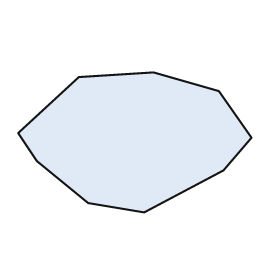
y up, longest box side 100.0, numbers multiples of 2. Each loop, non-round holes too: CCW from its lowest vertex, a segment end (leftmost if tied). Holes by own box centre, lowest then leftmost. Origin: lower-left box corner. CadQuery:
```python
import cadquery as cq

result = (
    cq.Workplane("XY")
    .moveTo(54.0, 0.0)
    .lineTo(88.0, 18.0)
    .lineTo(100.0, 32.0)
    .lineTo(86.0, 52.0)
    .lineTo(58.0, 60.0)
    .lineTo(26.0, 58.0)
    .lineTo(0.0, 34.0)
    .lineTo(8.0, 22.0)
    .lineTo(30.0, 4.0)
    .close()
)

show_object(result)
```